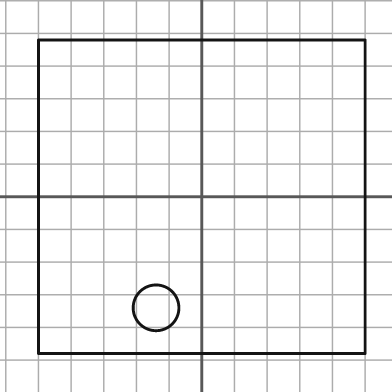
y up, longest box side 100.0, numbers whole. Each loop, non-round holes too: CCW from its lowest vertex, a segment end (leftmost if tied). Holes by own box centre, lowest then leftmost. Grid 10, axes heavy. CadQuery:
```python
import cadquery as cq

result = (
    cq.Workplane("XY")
    .moveTo(-50.0, -48.0)
    .lineTo(50.0, -48.0)
    .lineTo(50.0, 48.0)
    .lineTo(-50.0, 48.0)
    .close()
    .moveTo(-14.0, -34.0)
    .circle(7.0)
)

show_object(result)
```